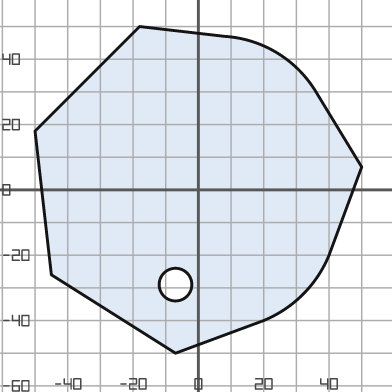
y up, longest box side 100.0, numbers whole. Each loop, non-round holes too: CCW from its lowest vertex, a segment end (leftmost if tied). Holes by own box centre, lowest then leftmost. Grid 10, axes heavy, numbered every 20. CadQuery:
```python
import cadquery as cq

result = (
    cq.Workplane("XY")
    .moveTo(-7.0, -50.0)
    .lineTo(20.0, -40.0)
    .threePointArc((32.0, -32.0), (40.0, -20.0))
    .lineTo(50.0, 7.0)
    .lineTo(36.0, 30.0)
    .threePointArc((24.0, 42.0), (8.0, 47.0))
    .lineTo(-18.0, 50.0)
    .lineTo(-50.0, 18.0)
    .lineTo(-45.0, -26.0)
    .close()
    .moveTo(-7.0, -29.0)
    .circle(5.0)
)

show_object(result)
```